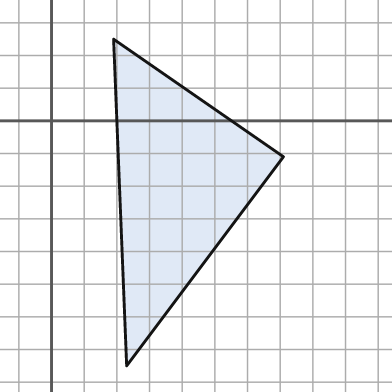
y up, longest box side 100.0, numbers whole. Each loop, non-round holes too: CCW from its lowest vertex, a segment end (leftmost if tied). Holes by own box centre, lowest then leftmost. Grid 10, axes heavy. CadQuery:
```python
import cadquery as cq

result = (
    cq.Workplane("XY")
    .moveTo(23.0, -75.0)
    .lineTo(71.0, -11.0)
    .lineTo(19.0, 25.0)
    .close()
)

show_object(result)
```